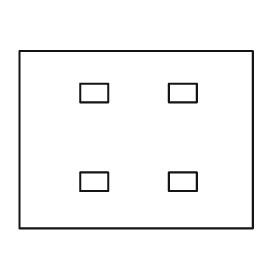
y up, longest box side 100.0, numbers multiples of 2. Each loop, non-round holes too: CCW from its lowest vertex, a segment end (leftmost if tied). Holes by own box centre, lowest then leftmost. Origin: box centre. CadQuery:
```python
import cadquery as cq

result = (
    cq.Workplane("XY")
    .moveTo(-50.0, -38.0)
    .lineTo(50.0, -38.0)
    .lineTo(50.0, 38.0)
    .lineTo(-50.0, 38.0)
    .close()
    .moveTo(-24.0, -22.0)
    .lineTo(-12.0, -22.0)
    .lineTo(-12.0, -14.0)
    .lineTo(-24.0, -14.0)
    .close()
    .moveTo(14.0, -22.0)
    .lineTo(26.0, -22.0)
    .lineTo(26.0, -14.0)
    .lineTo(14.0, -14.0)
    .close()
    .moveTo(-24.0, 16.0)
    .lineTo(-12.0, 16.0)
    .lineTo(-12.0, 24.0)
    .lineTo(-24.0, 24.0)
    .close()
    .moveTo(14.0, 16.0)
    .lineTo(26.0, 16.0)
    .lineTo(26.0, 24.0)
    .lineTo(14.0, 24.0)
    .close()
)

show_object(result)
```